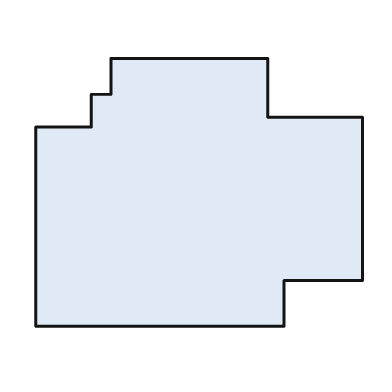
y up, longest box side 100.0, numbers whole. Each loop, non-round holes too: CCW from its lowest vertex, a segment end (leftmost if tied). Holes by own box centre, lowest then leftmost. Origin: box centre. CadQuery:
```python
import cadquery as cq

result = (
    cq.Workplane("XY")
    .moveTo(-50.0, -41.0)
    .lineTo(26.0, -41.0)
    .lineTo(26.0, -27.0)
    .lineTo(50.0, -27.0)
    .lineTo(50.0, 23.0)
    .lineTo(21.0, 23.0)
    .lineTo(21.0, 41.0)
    .lineTo(-27.0, 41.0)
    .lineTo(-27.0, 30.0)
    .lineTo(-33.0, 30.0)
    .lineTo(-33.0, 20.0)
    .lineTo(-50.0, 20.0)
    .close()
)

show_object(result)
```